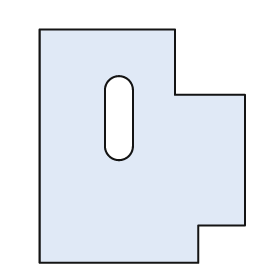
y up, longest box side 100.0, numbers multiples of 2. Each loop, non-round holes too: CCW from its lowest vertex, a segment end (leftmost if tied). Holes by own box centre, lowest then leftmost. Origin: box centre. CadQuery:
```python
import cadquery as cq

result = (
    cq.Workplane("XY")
    .moveTo(-44.0, -50.0)
    .lineTo(24.0, -50.0)
    .lineTo(24.0, -34.0)
    .lineTo(44.0, -34.0)
    .lineTo(44.0, 22.0)
    .lineTo(14.0, 22.0)
    .lineTo(14.0, 50.0)
    .lineTo(-44.0, 50.0)
    .close()
    .moveTo(-16.0, 0.0)
    .threePointArc((-10.0, -6.0), (-4.0, 0.0))
    .lineTo(-4.0, 24.0)
    .threePointArc((-10.0, 30.0), (-16.0, 24.0))
    .close()
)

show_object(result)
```